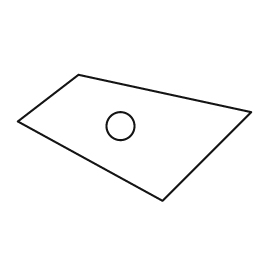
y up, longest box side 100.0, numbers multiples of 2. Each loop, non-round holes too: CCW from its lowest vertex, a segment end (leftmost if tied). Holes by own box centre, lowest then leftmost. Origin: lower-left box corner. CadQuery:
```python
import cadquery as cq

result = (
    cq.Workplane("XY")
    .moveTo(62.0, 0.0)
    .lineTo(100.0, 38.0)
    .lineTo(26.0, 54.0)
    .lineTo(0.0, 34.0)
    .close()
    .moveTo(44.0, 32.0)
    .circle(6.0)
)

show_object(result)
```